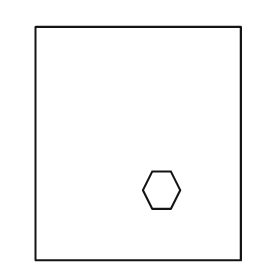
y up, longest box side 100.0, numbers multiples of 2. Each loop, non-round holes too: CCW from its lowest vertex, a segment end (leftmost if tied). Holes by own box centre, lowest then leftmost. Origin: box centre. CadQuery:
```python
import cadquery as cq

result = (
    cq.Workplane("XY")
    .moveTo(-44.0, -50.0)
    .lineTo(44.0, -50.0)
    .lineTo(44.0, 50.0)
    .lineTo(-44.0, 50.0)
    .close()
    .moveTo(6.0, -28.0)
    .lineTo(14.0, -28.0)
    .lineTo(18.0, -20.0)
    .lineTo(14.0, -12.0)
    .lineTo(6.0, -12.0)
    .lineTo(2.0, -20.0)
    .close()
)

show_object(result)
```